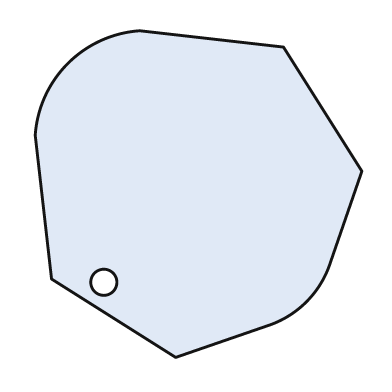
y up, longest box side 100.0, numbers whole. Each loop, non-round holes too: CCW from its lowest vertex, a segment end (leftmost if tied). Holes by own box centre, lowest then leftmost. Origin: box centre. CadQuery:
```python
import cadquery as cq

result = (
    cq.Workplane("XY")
    .moveTo(-7.0, -50.0)
    .lineTo(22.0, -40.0)
    .threePointArc((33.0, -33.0), (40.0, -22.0))
    .lineTo(50.0, 7.0)
    .lineTo(26.0, 45.0)
    .lineTo(-18.0, 50.0)
    .threePointArc((-40.0, 40.0), (-50.0, 18.0))
    .lineTo(-45.0, -26.0)
    .close()
    .moveTo(-29.0, -27.0)
    .circle(4.0)
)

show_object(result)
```